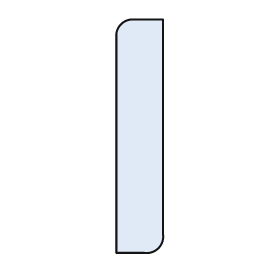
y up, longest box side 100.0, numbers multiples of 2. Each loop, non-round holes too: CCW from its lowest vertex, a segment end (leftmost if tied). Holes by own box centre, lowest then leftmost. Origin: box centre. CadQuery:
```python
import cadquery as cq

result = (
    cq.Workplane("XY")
    .moveTo(-10.0, -50.0)
    .lineTo(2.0, -50.0)
    .threePointArc((8.0, -48.0), (10.0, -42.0))
    .lineTo(10.0, 50.0)
    .lineTo(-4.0, 50.0)
    .threePointArc((-8.0, 48.0), (-10.0, 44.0))
    .close()
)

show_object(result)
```